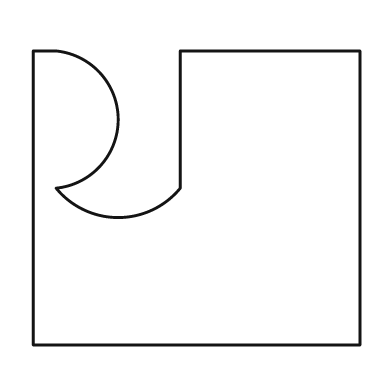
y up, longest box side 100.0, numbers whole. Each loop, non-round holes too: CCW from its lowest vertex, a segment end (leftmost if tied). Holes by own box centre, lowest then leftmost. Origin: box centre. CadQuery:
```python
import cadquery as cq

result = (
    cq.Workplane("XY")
    .moveTo(-50.0, -45.0)
    .lineTo(50.0, -45.0)
    .lineTo(50.0, 45.0)
    .lineTo(-5.0, 45.0)
    .lineTo(-5.0, 3.0)
    .threePointArc((-24.0, -6.0), (-43.0, 3.0))
    .threePointArc((-24.0, 24.0), (-43.0, 45.0))
    .lineTo(-50.0, 45.0)
    .close()
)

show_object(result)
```